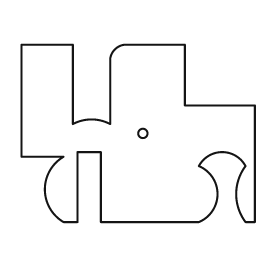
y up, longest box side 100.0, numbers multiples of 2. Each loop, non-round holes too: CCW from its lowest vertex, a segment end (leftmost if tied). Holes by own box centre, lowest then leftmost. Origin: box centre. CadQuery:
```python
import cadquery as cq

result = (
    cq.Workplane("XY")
    .moveTo(-32.0, -38.0)
    .lineTo(-26.0, -38.0)
    .lineTo(-26.0, -8.0)
    .lineTo(-16.0, -8.0)
    .lineTo(-16.0, -38.0)
    .lineTo(26.0, -38.0)
    .threePointArc((34.0, -26.0), (26.0, -14.0))
    .threePointArc((36.0, -8.0), (46.0, -14.0))
    .threePointArc((42.0, -26.0), (46.0, -38.0))
    .lineTo(50.0, -38.0)
    .lineTo(50.0, 12.0)
    .lineTo(20.0, 12.0)
    .lineTo(20.0, 38.0)
    .lineTo(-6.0, 38.0)
    .threePointArc((-10.0, 36.0), (-12.0, 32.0))
    .lineTo(-12.0, 4.0)
    .threePointArc((-20.0, 6.0), (-28.0, 4.0))
    .lineTo(-28.0, 38.0)
    .lineTo(-50.0, 38.0)
    .lineTo(-50.0, -10.0)
    .lineTo(-32.0, -10.0)
    .threePointArc((-40.0, -24.0), (-32.0, -38.0))
    .close()
    .moveTo(2.0, 0.0)
    .circle(2.0)
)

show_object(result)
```